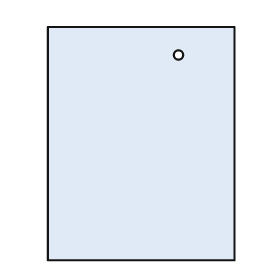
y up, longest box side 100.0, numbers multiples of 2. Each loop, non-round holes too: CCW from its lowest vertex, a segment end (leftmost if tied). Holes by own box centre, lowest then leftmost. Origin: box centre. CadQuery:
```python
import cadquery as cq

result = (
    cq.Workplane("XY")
    .moveTo(-40.0, -50.0)
    .lineTo(40.0, -50.0)
    .lineTo(40.0, 50.0)
    .lineTo(-40.0, 50.0)
    .close()
    .moveTo(16.0, 38.0)
    .circle(2.0)
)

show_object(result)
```